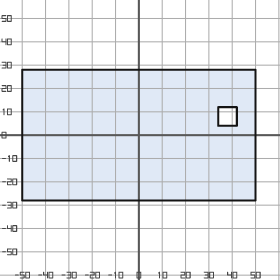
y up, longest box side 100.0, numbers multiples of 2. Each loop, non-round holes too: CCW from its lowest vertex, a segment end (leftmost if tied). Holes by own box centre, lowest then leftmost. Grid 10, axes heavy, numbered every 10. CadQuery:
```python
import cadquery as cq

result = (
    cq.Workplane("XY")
    .moveTo(-50.0, -28.0)
    .lineTo(50.0, -28.0)
    .lineTo(50.0, 28.0)
    .lineTo(-50.0, 28.0)
    .close()
    .moveTo(34.0, 4.0)
    .lineTo(42.0, 4.0)
    .lineTo(42.0, 12.0)
    .lineTo(34.0, 12.0)
    .close()
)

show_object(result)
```